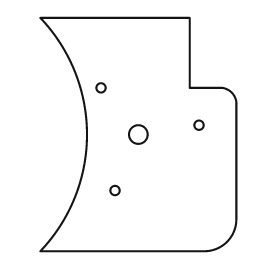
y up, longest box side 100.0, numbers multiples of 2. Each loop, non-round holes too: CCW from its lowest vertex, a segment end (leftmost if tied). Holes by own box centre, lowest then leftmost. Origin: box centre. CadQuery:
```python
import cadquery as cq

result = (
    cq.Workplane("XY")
    .moveTo(-42.0, -50.0)
    .lineTo(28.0, -50.0)
    .threePointArc((38.0, -46.0), (42.0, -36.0))
    .lineTo(42.0, 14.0)
    .threePointArc((40.0, 18.0), (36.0, 20.0))
    .lineTo(22.0, 20.0)
    .lineTo(22.0, 50.0)
    .lineTo(-42.0, 50.0)
    .threePointArc((-22.0, 0.0), (-42.0, -50.0))
    .close()
    .moveTo(-10.0, -24.0)
    .circle(2.0)
    .moveTo(0.0, 0.0)
    .circle(4.0)
    .moveTo(26.0, 4.0)
    .circle(2.0)
    .moveTo(-16.0, 20.0)
    .circle(2.0)
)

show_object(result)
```